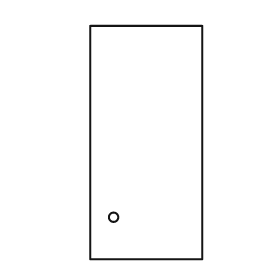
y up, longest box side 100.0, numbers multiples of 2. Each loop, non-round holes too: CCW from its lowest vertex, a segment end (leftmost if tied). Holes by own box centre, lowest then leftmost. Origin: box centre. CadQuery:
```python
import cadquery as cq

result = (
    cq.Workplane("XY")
    .moveTo(-24.0, -50.0)
    .lineTo(24.0, -50.0)
    .lineTo(24.0, 50.0)
    .lineTo(-24.0, 50.0)
    .close()
    .moveTo(-14.0, -32.0)
    .circle(2.0)
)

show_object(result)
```